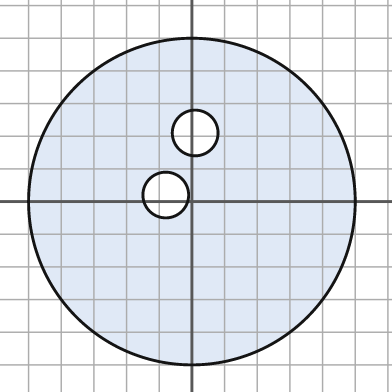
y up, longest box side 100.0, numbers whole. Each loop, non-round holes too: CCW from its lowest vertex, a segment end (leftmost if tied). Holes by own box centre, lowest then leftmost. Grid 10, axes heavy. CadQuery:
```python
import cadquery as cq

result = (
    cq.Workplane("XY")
    .moveTo(0.0, 0.0)
    .circle(50.0)
    .moveTo(-8.0, 2.0)
    .circle(7.0)
    .moveTo(1.0, 21.0)
    .circle(7.0)
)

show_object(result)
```